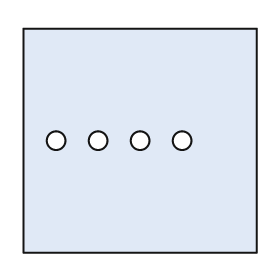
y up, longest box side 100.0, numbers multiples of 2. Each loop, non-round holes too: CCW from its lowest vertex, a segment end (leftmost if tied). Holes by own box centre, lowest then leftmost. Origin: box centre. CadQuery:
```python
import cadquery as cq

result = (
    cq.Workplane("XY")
    .moveTo(-50.0, -48.0)
    .lineTo(50.0, -48.0)
    .lineTo(50.0, 48.0)
    .lineTo(-50.0, 48.0)
    .close()
    .moveTo(-36.0, 0.0)
    .circle(4.0)
    .moveTo(-18.0, 0.0)
    .circle(4.0)
    .moveTo(0.0, 0.0)
    .circle(4.0)
    .moveTo(18.0, 0.0)
    .circle(4.0)
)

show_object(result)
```